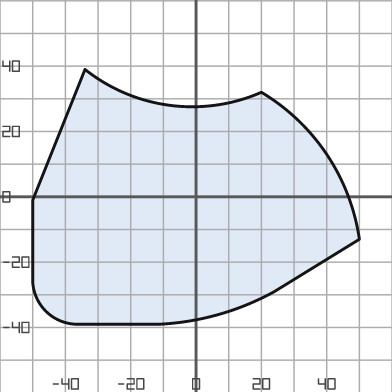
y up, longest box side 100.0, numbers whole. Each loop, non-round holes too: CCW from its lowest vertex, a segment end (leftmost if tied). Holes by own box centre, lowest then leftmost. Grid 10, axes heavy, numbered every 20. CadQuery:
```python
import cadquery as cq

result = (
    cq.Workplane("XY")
    .moveTo(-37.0, -39.0)
    .lineTo(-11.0, -39.0)
    .threePointArc((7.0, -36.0), (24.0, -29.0))
    .lineTo(50.0, -13.0)
    .threePointArc((40.0, 13.0), (20.0, 32.0))
    .threePointArc((-8.0, 28.0), (-34.0, 39.0))
    .lineTo(-50.0, -1.0)
    .lineTo(-50.0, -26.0)
    .threePointArc((-46.0, -35.0), (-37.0, -39.0))
    .close()
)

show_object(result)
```